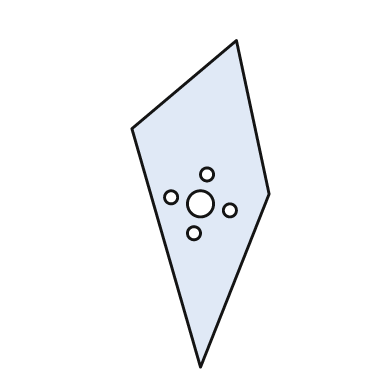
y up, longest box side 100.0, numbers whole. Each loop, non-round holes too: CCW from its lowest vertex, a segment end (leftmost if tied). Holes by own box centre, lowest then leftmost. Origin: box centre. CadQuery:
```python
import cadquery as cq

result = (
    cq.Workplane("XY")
    .moveTo(0.0, -50.0)
    .lineTo(21.0, 3.0)
    .lineTo(11.0, 50.0)
    .lineTo(-21.0, 23.0)
    .close()
    .moveTo(-2.0, -9.0)
    .circle(2.0)
    .moveTo(9.0, -2.0)
    .circle(2.0)
    .moveTo(0.0, 0.0)
    .circle(4.0)
    .moveTo(-9.0, 2.0)
    .circle(2.0)
    .moveTo(2.0, 9.0)
    .circle(2.0)
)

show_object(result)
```